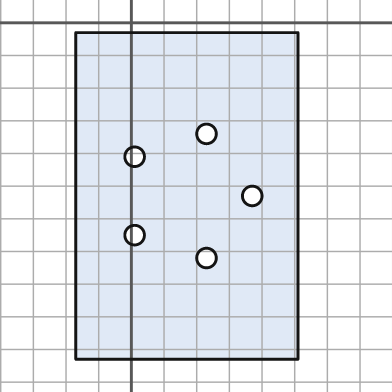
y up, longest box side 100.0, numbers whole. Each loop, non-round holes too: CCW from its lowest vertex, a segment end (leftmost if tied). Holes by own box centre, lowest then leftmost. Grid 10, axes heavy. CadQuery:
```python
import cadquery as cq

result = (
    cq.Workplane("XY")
    .moveTo(-17.0, -103.0)
    .lineTo(51.0, -103.0)
    .lineTo(51.0, -3.0)
    .lineTo(-17.0, -3.0)
    .close()
    .moveTo(23.0, -72.0)
    .circle(3.0)
    .moveTo(1.0, -65.0)
    .circle(3.0)
    .moveTo(37.0, -53.0)
    .circle(3.0)
    .moveTo(1.0, -41.0)
    .circle(3.0)
    .moveTo(23.0, -34.0)
    .circle(3.0)
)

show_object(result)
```